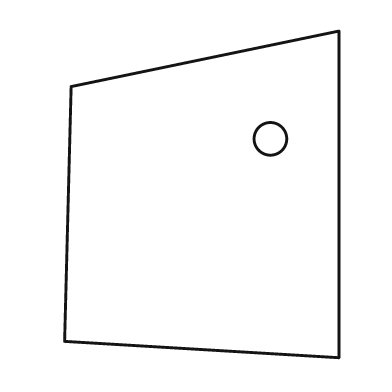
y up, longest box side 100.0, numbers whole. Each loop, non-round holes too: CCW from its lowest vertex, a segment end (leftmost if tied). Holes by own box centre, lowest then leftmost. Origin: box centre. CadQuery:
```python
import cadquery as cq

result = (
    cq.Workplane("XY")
    .moveTo(42.0, -50.0)
    .lineTo(42.0, 50.0)
    .lineTo(-40.0, 33.0)
    .lineTo(-42.0, -45.0)
    .close()
    .moveTo(21.0, 17.0)
    .circle(5.0)
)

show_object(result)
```